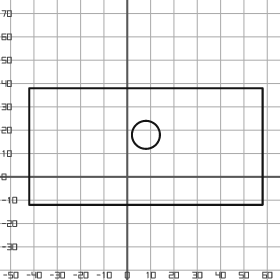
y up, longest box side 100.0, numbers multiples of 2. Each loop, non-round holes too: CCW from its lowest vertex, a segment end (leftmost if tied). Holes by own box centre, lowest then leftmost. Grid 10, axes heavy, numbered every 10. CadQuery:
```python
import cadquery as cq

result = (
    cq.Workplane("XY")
    .moveTo(-42.0, -12.0)
    .lineTo(58.0, -12.0)
    .lineTo(58.0, 38.0)
    .lineTo(-42.0, 38.0)
    .close()
    .moveTo(8.0, 18.0)
    .circle(6.0)
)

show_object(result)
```